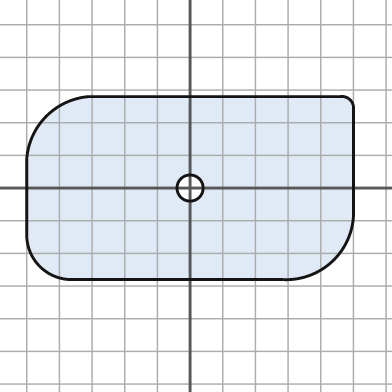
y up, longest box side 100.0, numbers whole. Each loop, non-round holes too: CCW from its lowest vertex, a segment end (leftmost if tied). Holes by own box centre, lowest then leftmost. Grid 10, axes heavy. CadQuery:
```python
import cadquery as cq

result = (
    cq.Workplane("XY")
    .moveTo(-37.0, -28.0)
    .lineTo(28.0, -28.0)
    .threePointArc((44.0, -22.0), (50.0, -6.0))
    .lineTo(50.0, 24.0)
    .threePointArc((49.0, 27.0), (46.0, 28.0))
    .lineTo(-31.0, 28.0)
    .threePointArc((-44.0, 22.0), (-50.0, 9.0))
    .lineTo(-50.0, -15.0)
    .threePointArc((-46.0, -24.0), (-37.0, -28.0))
    .close()
    .moveTo(0.0, 0.0)
    .circle(4.0)
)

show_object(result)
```